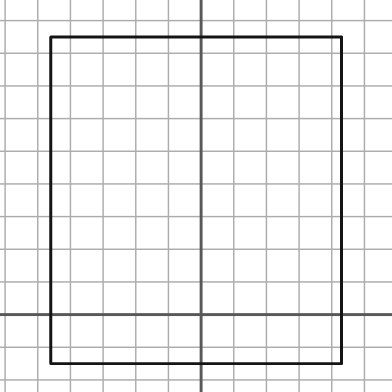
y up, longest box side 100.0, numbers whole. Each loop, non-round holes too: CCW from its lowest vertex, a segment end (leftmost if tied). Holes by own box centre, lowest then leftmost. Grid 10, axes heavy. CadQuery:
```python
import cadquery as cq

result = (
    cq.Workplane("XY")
    .moveTo(-46.0, -15.0)
    .lineTo(43.0, -15.0)
    .lineTo(43.0, 85.0)
    .lineTo(-46.0, 85.0)
    .close()
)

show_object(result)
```